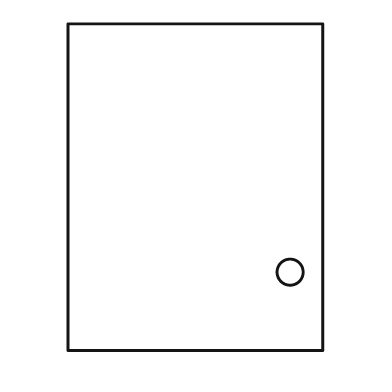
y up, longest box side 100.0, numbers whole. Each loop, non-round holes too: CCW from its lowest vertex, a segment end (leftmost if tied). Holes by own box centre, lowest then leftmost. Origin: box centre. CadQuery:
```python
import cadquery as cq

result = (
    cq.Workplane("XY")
    .moveTo(-39.0, -50.0)
    .lineTo(39.0, -50.0)
    .lineTo(39.0, 50.0)
    .lineTo(-39.0, 50.0)
    .close()
    .moveTo(29.0, -26.0)
    .circle(4.0)
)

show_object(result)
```